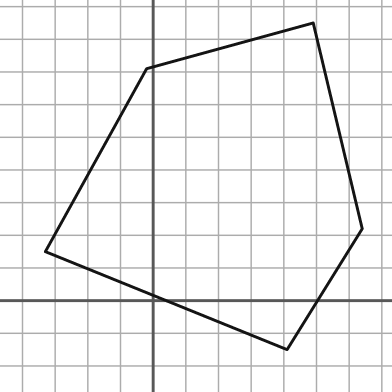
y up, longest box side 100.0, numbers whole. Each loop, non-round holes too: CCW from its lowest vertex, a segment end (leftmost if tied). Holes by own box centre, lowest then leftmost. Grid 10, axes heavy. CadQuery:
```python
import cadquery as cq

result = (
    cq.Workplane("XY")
    .moveTo(41.0, -15.0)
    .lineTo(64.0, 22.0)
    .lineTo(49.0, 85.0)
    .lineTo(-2.0, 71.0)
    .lineTo(-33.0, 15.0)
    .close()
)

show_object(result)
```